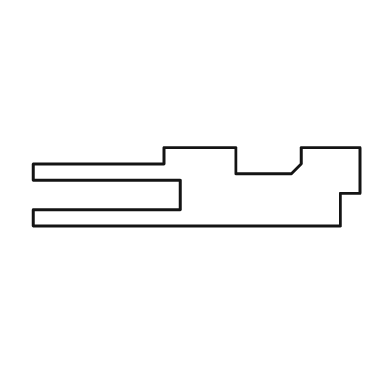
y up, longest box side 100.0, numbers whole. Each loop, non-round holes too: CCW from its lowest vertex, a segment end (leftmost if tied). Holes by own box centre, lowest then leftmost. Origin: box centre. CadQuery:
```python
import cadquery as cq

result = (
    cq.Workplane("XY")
    .moveTo(-50.0, -12.0)
    .lineTo(44.0, -12.0)
    .lineTo(44.0, -2.0)
    .lineTo(50.0, -2.0)
    .lineTo(50.0, 12.0)
    .lineTo(32.0, 12.0)
    .lineTo(32.0, 7.0)
    .lineTo(29.0, 4.0)
    .lineTo(12.0, 4.0)
    .lineTo(12.0, 12.0)
    .lineTo(-10.0, 12.0)
    .lineTo(-10.0, 7.0)
    .lineTo(-50.0, 7.0)
    .lineTo(-50.0, 2.0)
    .lineTo(-5.0, 2.0)
    .lineTo(-5.0, -7.0)
    .lineTo(-50.0, -7.0)
    .close()
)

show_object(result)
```